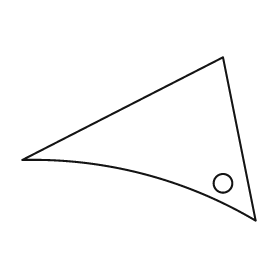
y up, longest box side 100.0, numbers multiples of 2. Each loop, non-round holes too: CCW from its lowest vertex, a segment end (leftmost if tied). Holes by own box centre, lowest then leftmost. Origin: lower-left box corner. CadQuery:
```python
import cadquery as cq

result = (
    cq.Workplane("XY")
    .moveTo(100.0, 0.0)
    .lineTo(86.0, 70.0)
    .lineTo(0.0, 26.0)
    .threePointArc((52.0, 20.0), (100.0, 0.0))
    .close()
    .moveTo(86.0, 16.0)
    .circle(4.0)
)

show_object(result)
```